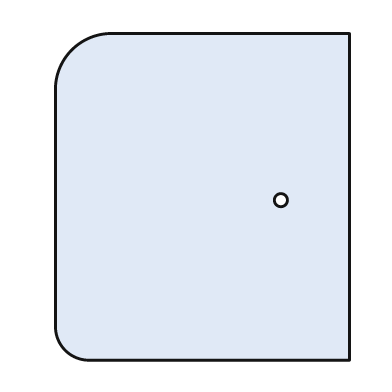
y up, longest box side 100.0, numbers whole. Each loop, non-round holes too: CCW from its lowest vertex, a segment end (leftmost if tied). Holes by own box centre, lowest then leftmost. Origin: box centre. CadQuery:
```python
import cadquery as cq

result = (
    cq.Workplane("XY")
    .moveTo(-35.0, -50.0)
    .lineTo(45.0, -50.0)
    .lineTo(45.0, 50.0)
    .lineTo(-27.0, 50.0)
    .threePointArc((-40.0, 45.0), (-45.0, 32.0))
    .lineTo(-45.0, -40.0)
    .threePointArc((-42.0, -47.0), (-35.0, -50.0))
    .close()
    .moveTo(24.0, -1.0)
    .circle(2.0)
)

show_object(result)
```